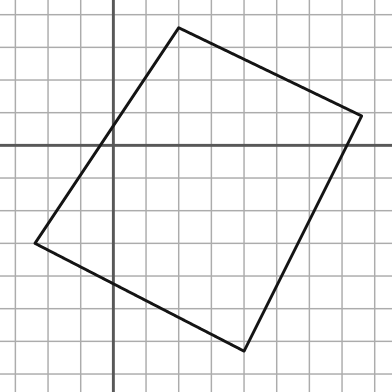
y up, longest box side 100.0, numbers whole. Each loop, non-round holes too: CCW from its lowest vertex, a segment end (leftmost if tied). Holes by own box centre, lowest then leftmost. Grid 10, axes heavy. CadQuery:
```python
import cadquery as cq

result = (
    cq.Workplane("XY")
    .moveTo(40.0, -63.0)
    .lineTo(76.0, 9.0)
    .lineTo(20.0, 36.0)
    .lineTo(-24.0, -30.0)
    .close()
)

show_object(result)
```